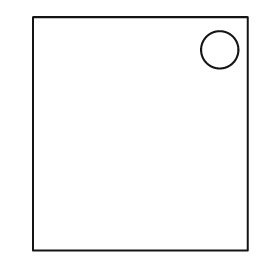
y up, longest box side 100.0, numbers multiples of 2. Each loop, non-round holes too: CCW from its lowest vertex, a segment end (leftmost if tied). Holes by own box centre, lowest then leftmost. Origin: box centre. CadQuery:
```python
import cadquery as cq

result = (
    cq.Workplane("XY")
    .moveTo(-46.0, -50.0)
    .lineTo(46.0, -50.0)
    .lineTo(46.0, 50.0)
    .lineTo(-46.0, 50.0)
    .close()
    .moveTo(34.0, 36.0)
    .circle(8.0)
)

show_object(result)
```